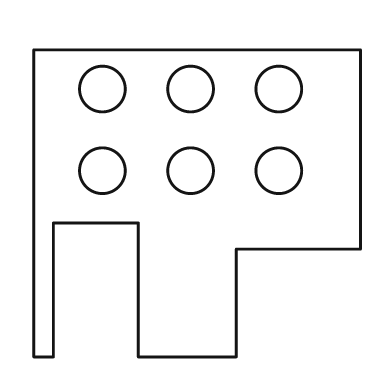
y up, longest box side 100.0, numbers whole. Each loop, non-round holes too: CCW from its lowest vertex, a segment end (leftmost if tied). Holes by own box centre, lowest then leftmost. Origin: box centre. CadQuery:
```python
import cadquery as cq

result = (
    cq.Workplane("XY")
    .moveTo(-50.0, -47.0)
    .lineTo(-44.0, -47.0)
    .lineTo(-44.0, -6.0)
    .lineTo(-18.0, -6.0)
    .lineTo(-18.0, -47.0)
    .lineTo(12.0, -47.0)
    .lineTo(12.0, -14.0)
    .lineTo(50.0, -14.0)
    .lineTo(50.0, 47.0)
    .lineTo(-50.0, 47.0)
    .close()
    .moveTo(-29.0, 10.0)
    .circle(7.0)
    .moveTo(-2.0, 10.0)
    .circle(7.0)
    .moveTo(25.0, 10.0)
    .circle(7.0)
    .moveTo(-29.0, 35.0)
    .circle(7.0)
    .moveTo(-2.0, 35.0)
    .circle(7.0)
    .moveTo(25.0, 35.0)
    .circle(7.0)
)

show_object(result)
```